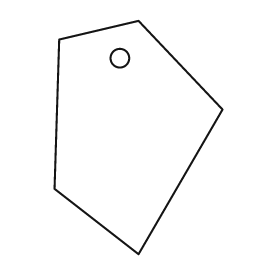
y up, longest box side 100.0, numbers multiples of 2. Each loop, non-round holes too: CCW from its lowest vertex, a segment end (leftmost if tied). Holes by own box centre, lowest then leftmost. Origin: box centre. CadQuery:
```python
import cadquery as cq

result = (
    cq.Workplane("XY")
    .moveTo(0.0, -50.0)
    .lineTo(36.0, 12.0)
    .lineTo(0.0, 50.0)
    .lineTo(-34.0, 42.0)
    .lineTo(-36.0, -22.0)
    .close()
    .moveTo(-8.0, 34.0)
    .circle(4.0)
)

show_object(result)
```